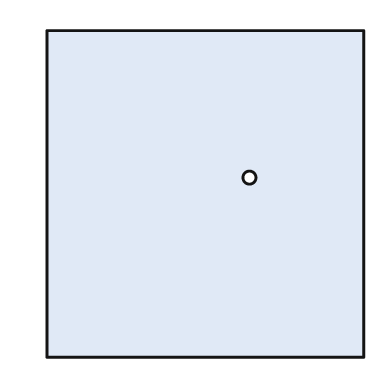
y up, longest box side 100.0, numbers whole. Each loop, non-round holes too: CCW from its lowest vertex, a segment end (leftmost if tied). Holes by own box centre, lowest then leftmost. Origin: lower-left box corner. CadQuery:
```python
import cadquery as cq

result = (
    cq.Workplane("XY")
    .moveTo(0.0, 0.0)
    .lineTo(97.0, 0.0)
    .lineTo(97.0, 100.0)
    .lineTo(0.0, 100.0)
    .close()
    .moveTo(62.0, 55.0)
    .circle(2.0)
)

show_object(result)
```